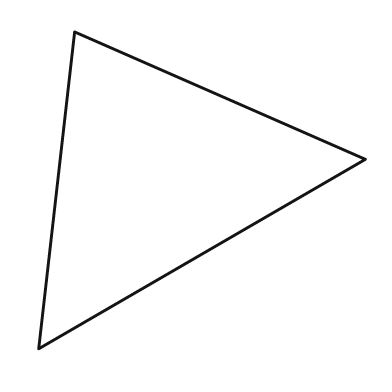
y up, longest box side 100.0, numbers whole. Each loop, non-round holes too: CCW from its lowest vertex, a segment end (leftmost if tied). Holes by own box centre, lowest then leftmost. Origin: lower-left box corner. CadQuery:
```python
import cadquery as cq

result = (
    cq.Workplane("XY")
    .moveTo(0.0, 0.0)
    .lineTo(100.0, 58.0)
    .lineTo(11.0, 97.0)
    .close()
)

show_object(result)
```